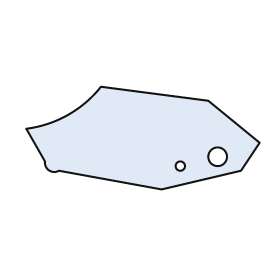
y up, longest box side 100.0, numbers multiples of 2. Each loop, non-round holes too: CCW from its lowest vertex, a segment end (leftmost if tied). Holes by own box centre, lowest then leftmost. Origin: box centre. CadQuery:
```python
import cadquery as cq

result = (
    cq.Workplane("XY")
    .moveTo(8.0, -22.0)
    .lineTo(42.0, -14.0)
    .lineTo(50.0, -2.0)
    .lineTo(28.0, 16.0)
    .lineTo(-18.0, 22.0)
    .threePointArc((-32.0, 10.0), (-50.0, 4.0))
    .lineTo(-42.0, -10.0)
    .threePointArc((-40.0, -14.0), (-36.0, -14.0))
    .close()
    .moveTo(16.0, -12.0)
    .circle(2.0)
    .moveTo(32.0, -8.0)
    .circle(4.0)
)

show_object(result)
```